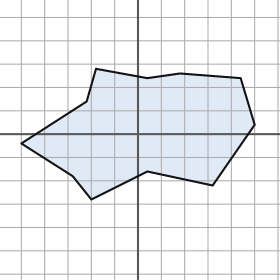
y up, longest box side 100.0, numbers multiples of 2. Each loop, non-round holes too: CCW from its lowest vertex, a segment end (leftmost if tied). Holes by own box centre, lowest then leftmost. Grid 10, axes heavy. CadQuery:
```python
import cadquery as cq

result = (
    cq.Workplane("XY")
    .moveTo(-20.0, -28.0)
    .lineTo(4.0, -16.0)
    .lineTo(32.0, -22.0)
    .lineTo(50.0, 4.0)
    .lineTo(44.0, 24.0)
    .lineTo(18.0, 26.0)
    .lineTo(4.0, 24.0)
    .lineTo(-18.0, 28.0)
    .lineTo(-22.0, 14.0)
    .lineTo(-50.0, -4.0)
    .lineTo(-28.0, -18.0)
    .close()
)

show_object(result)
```